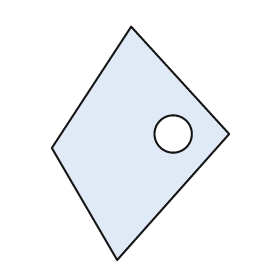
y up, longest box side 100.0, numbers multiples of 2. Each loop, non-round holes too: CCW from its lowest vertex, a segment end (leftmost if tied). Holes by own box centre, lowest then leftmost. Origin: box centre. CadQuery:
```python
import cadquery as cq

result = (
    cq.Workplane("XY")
    .moveTo(-10.0, -50.0)
    .lineTo(38.0, 4.0)
    .lineTo(-4.0, 50.0)
    .lineTo(-38.0, -2.0)
    .close()
    .moveTo(14.0, 4.0)
    .circle(8.0)
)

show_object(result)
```